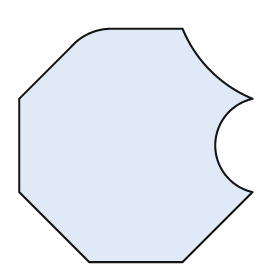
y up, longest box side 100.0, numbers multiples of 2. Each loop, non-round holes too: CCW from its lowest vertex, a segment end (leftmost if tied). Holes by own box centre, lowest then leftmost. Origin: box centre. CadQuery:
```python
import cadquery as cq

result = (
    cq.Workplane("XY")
    .moveTo(-20.0, -50.0)
    .lineTo(20.0, -50.0)
    .lineTo(50.0, -20.0)
    .threePointArc((34.0, 0.0), (50.0, 20.0))
    .threePointArc((32.0, 32.0), (20.0, 50.0))
    .lineTo(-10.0, 50.0)
    .threePointArc((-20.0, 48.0), (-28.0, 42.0))
    .lineTo(-50.0, 20.0)
    .lineTo(-50.0, -20.0)
    .close()
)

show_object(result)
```